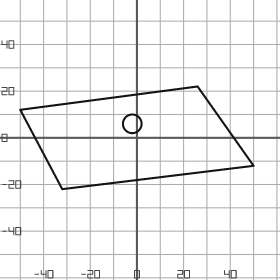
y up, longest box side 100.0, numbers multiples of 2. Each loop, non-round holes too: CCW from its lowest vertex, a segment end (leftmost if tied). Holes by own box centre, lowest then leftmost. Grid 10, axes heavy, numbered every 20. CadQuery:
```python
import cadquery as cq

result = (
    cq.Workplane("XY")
    .moveTo(-32.0, -22.0)
    .lineTo(50.0, -12.0)
    .lineTo(26.0, 22.0)
    .lineTo(-50.0, 12.0)
    .close()
    .moveTo(-2.0, 6.0)
    .circle(4.0)
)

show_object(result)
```